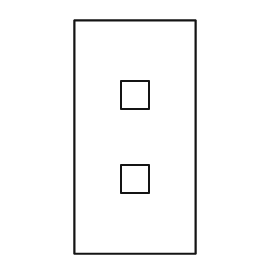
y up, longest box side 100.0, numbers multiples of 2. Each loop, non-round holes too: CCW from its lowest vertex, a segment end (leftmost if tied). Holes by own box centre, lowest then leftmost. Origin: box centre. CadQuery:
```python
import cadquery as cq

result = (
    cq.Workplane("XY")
    .moveTo(-26.0, -50.0)
    .lineTo(26.0, -50.0)
    .lineTo(26.0, 50.0)
    .lineTo(-26.0, 50.0)
    .close()
    .moveTo(-6.0, -24.0)
    .lineTo(6.0, -24.0)
    .lineTo(6.0, -12.0)
    .lineTo(-6.0, -12.0)
    .close()
    .moveTo(-6.0, 12.0)
    .lineTo(6.0, 12.0)
    .lineTo(6.0, 24.0)
    .lineTo(-6.0, 24.0)
    .close()
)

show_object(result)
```